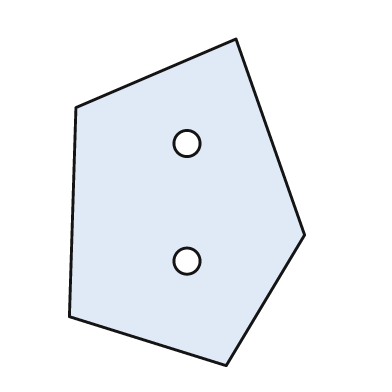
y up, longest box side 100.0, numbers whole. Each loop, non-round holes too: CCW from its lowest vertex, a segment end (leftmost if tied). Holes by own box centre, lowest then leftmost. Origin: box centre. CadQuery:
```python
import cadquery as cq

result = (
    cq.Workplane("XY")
    .moveTo(12.0, -50.0)
    .lineTo(36.0, -10.0)
    .lineTo(15.0, 50.0)
    .lineTo(-34.0, 29.0)
    .lineTo(-36.0, -35.0)
    .close()
    .moveTo(0.0, -18.0)
    .circle(4.0)
    .moveTo(0.0, 18.0)
    .circle(4.0)
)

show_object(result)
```